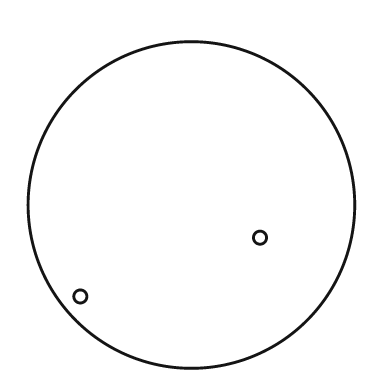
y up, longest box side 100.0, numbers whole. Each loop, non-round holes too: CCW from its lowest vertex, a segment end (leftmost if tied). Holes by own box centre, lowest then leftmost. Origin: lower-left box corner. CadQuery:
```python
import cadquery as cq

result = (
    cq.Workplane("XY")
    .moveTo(50.0, 50.0)
    .circle(50.0)
    .moveTo(16.0, 22.0)
    .circle(2.0)
    .moveTo(71.0, 40.0)
    .circle(2.0)
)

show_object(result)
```